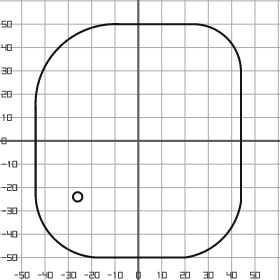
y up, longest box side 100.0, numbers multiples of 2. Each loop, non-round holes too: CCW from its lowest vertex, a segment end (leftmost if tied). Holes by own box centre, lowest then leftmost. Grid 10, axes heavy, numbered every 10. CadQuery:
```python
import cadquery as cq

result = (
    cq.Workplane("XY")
    .moveTo(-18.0, -50.0)
    .lineTo(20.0, -50.0)
    .threePointArc((36.0, -42.0), (44.0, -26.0))
    .lineTo(44.0, 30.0)
    .threePointArc((38.0, 44.0), (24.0, 50.0))
    .lineTo(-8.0, 50.0)
    .threePointArc((-34.0, 40.0), (-44.0, 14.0))
    .lineTo(-44.0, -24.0)
    .threePointArc((-36.0, -42.0), (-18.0, -50.0))
    .close()
    .moveTo(-26.0, -24.0)
    .circle(2.0)
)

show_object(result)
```